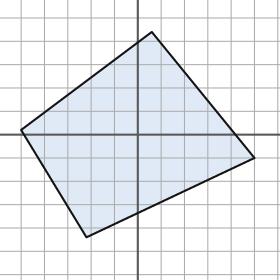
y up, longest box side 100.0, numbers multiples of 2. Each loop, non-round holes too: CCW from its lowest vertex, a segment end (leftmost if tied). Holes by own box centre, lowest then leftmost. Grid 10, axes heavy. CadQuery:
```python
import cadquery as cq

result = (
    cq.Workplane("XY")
    .moveTo(-22.0, -44.0)
    .lineTo(50.0, -10.0)
    .lineTo(6.0, 44.0)
    .lineTo(-50.0, 2.0)
    .close()
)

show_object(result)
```